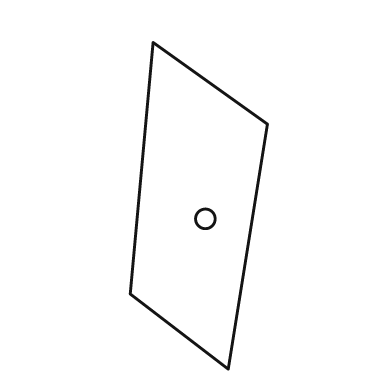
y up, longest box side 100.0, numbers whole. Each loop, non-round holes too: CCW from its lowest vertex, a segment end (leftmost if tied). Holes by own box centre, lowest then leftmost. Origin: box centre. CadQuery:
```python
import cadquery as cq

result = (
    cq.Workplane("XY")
    .moveTo(9.0, -50.0)
    .lineTo(21.0, 25.0)
    .lineTo(-14.0, 50.0)
    .lineTo(-21.0, -27.0)
    .close()
    .moveTo(2.0, -4.0)
    .circle(3.0)
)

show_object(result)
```